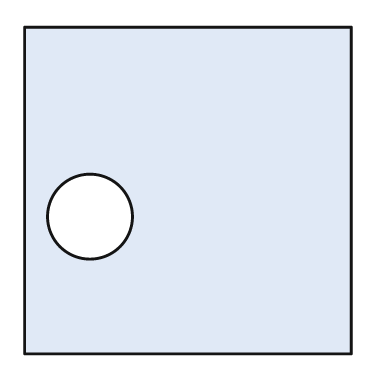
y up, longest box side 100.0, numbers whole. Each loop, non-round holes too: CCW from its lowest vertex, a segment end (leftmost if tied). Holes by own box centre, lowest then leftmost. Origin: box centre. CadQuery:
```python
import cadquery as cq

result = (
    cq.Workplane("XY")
    .moveTo(-50.0, -50.0)
    .lineTo(50.0, -50.0)
    .lineTo(50.0, 50.0)
    .lineTo(-50.0, 50.0)
    .close()
    .moveTo(-30.0, -8.0)
    .circle(13.0)
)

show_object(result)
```